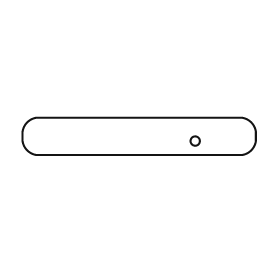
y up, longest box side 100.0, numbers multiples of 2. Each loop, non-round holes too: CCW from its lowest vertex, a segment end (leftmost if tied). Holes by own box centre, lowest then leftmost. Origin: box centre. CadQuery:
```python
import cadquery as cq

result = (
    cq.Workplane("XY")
    .moveTo(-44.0, -8.0)
    .lineTo(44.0, -8.0)
    .threePointArc((48.0, -6.0), (50.0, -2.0))
    .lineTo(50.0, 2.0)
    .threePointArc((48.0, 6.0), (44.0, 8.0))
    .lineTo(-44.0, 8.0)
    .threePointArc((-48.0, 6.0), (-50.0, 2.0))
    .lineTo(-50.0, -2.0)
    .threePointArc((-48.0, -6.0), (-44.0, -8.0))
    .close()
    .moveTo(24.0, -2.0)
    .circle(2.0)
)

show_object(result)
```